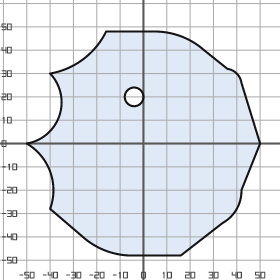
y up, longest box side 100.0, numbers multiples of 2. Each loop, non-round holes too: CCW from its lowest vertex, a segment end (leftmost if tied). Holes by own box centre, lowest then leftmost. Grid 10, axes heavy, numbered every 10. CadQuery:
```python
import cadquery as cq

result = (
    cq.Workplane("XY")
    .moveTo(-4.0, -48.0)
    .lineTo(16.0, -48.0)
    .lineTo(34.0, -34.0)
    .threePointArc((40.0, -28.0), (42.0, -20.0))
    .lineTo(50.0, 0.0)
    .lineTo(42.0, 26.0)
    .threePointArc((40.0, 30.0), (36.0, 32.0))
    .lineTo(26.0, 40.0)
    .threePointArc((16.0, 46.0), (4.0, 48.0))
    .lineTo(-16.0, 48.0)
    .threePointArc((-26.0, 36.0), (-40.0, 30.0))
    .threePointArc((-36.0, 12.0), (-50.0, 0.0))
    .threePointArc((-40.0, -12.0), (-40.0, -28.0))
    .lineTo(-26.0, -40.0)
    .threePointArc((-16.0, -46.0), (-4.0, -48.0))
    .close()
    .moveTo(-4.0, 20.0)
    .circle(4.0)
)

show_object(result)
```